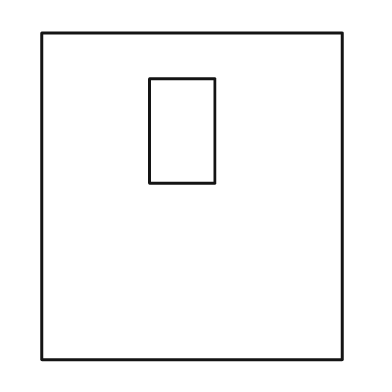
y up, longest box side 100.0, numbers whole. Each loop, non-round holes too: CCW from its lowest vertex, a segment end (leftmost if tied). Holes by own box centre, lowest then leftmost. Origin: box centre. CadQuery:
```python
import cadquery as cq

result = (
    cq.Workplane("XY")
    .moveTo(-46.0, -50.0)
    .lineTo(46.0, -50.0)
    .lineTo(46.0, 50.0)
    .lineTo(-46.0, 50.0)
    .close()
    .moveTo(-13.0, 4.0)
    .lineTo(7.0, 4.0)
    .lineTo(7.0, 36.0)
    .lineTo(-13.0, 36.0)
    .close()
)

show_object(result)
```